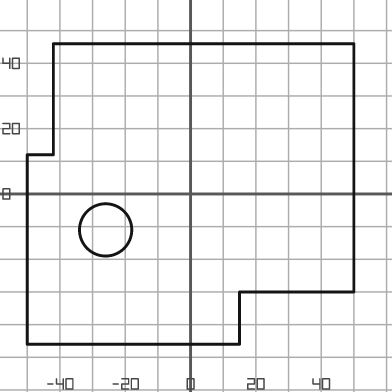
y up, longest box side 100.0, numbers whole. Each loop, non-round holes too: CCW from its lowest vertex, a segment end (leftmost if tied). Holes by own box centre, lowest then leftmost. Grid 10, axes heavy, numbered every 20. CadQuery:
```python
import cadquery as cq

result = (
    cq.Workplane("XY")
    .moveTo(-50.0, -46.0)
    .lineTo(15.0, -46.0)
    .lineTo(15.0, -30.0)
    .lineTo(50.0, -30.0)
    .lineTo(50.0, 46.0)
    .lineTo(-42.0, 46.0)
    .lineTo(-42.0, 12.0)
    .lineTo(-50.0, 12.0)
    .close()
    .moveTo(-26.0, -11.0)
    .circle(8.0)
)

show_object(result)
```